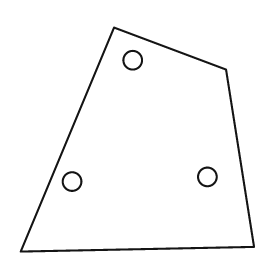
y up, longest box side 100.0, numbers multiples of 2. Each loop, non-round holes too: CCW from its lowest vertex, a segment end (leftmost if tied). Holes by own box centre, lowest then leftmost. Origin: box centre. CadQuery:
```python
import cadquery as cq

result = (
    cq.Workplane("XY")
    .moveTo(-50.0, -48.0)
    .lineTo(50.0, -46.0)
    .lineTo(38.0, 30.0)
    .lineTo(-10.0, 48.0)
    .close()
    .moveTo(-28.0, -18.0)
    .circle(4.0)
    .moveTo(30.0, -16.0)
    .circle(4.0)
    .moveTo(-2.0, 34.0)
    .circle(4.0)
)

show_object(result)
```